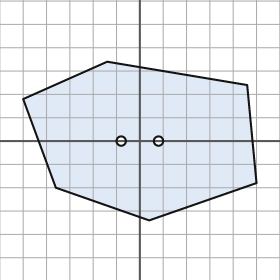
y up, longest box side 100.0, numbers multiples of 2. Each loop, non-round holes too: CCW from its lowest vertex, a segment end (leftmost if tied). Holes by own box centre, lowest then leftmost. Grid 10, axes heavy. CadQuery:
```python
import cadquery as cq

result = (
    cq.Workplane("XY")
    .moveTo(4.0, -34.0)
    .lineTo(50.0, -18.0)
    .lineTo(46.0, 24.0)
    .lineTo(-14.0, 34.0)
    .lineTo(-50.0, 18.0)
    .lineTo(-36.0, -20.0)
    .close()
    .moveTo(-8.0, 0.0)
    .circle(2.0)
    .moveTo(8.0, 0.0)
    .circle(2.0)
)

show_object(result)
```